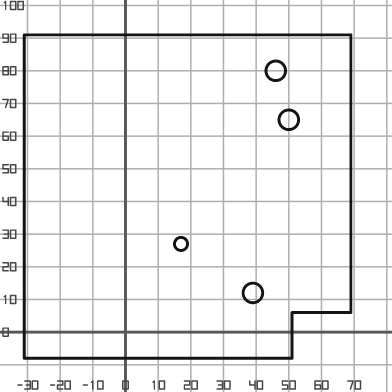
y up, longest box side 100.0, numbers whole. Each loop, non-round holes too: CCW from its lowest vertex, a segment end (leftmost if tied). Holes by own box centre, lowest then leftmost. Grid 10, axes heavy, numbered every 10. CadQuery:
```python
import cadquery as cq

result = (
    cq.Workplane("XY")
    .moveTo(-31.0, -8.0)
    .lineTo(51.0, -8.0)
    .lineTo(51.0, 6.0)
    .lineTo(69.0, 6.0)
    .lineTo(69.0, 91.0)
    .lineTo(-31.0, 91.0)
    .close()
    .moveTo(39.0, 12.0)
    .circle(3.0)
    .moveTo(17.0, 27.0)
    .circle(2.0)
    .moveTo(50.0, 65.0)
    .circle(3.0)
    .moveTo(46.0, 80.0)
    .circle(3.0)
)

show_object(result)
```